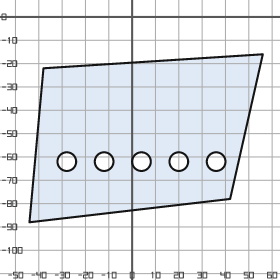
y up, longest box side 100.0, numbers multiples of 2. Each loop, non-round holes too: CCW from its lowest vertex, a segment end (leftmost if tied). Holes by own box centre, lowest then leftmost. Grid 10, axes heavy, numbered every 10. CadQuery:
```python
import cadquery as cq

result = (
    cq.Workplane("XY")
    .moveTo(-44.0, -88.0)
    .lineTo(42.0, -78.0)
    .lineTo(56.0, -16.0)
    .lineTo(-38.0, -22.0)
    .close()
    .moveTo(-28.0, -62.0)
    .circle(4.0)
    .moveTo(-12.0, -62.0)
    .circle(4.0)
    .moveTo(4.0, -62.0)
    .circle(4.0)
    .moveTo(20.0, -62.0)
    .circle(4.0)
    .moveTo(36.0, -62.0)
    .circle(4.0)
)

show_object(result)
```